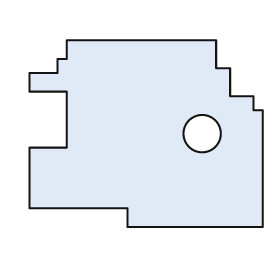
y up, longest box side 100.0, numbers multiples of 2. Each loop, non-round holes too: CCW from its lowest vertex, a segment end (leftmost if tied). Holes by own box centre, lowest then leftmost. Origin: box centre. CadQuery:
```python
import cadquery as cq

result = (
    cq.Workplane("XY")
    .moveTo(-8.0, -40.0)
    .lineTo(50.0, -40.0)
    .lineTo(50.0, 10.0)
    .lineTo(46.0, 10.0)
    .lineTo(46.0, 16.0)
    .lineTo(36.0, 16.0)
    .lineTo(36.0, 28.0)
    .lineTo(30.0, 28.0)
    .lineTo(30.0, 40.0)
    .lineTo(-34.0, 40.0)
    .lineTo(-34.0, 32.0)
    .lineTo(-38.0, 32.0)
    .lineTo(-38.0, 26.0)
    .lineTo(-50.0, 26.0)
    .lineTo(-50.0, 18.0)
    .lineTo(-34.0, 18.0)
    .lineTo(-34.0, -6.0)
    .lineTo(-50.0, -6.0)
    .lineTo(-50.0, -32.0)
    .lineTo(-8.0, -32.0)
    .close()
    .moveTo(24.0, 0.0)
    .circle(8.0)
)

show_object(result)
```